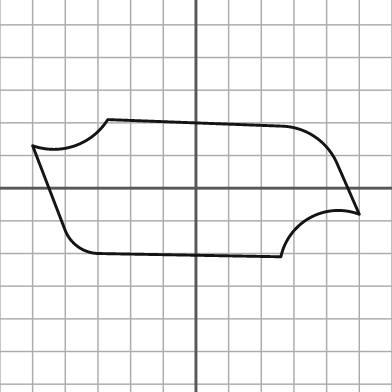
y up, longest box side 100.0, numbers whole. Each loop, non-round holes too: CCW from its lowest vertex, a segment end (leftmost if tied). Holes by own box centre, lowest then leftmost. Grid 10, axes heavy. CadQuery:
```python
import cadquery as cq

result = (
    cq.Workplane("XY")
    .moveTo(26.0, -21.0)
    .threePointArc((35.0, -9.0), (50.0, -8.0))
    .lineTo(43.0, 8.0)
    .threePointArc((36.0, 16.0), (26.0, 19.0))
    .lineTo(-27.0, 21.0)
    .threePointArc((-37.0, 13.0), (-50.0, 13.0))
    .lineTo(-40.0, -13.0)
    .threePointArc((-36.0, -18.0), (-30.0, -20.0))
    .close()
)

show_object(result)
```